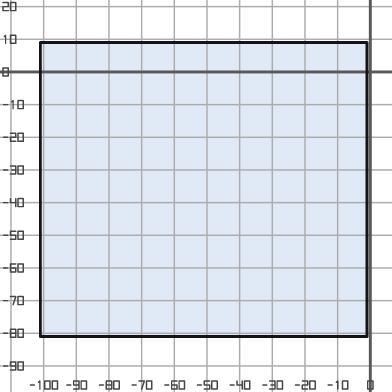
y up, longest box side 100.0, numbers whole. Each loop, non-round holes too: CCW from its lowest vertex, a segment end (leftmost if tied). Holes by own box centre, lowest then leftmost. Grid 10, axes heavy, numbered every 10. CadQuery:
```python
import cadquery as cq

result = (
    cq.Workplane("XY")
    .moveTo(-101.0, -81.0)
    .lineTo(-1.0, -81.0)
    .lineTo(-1.0, 9.0)
    .lineTo(-101.0, 9.0)
    .close()
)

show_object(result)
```